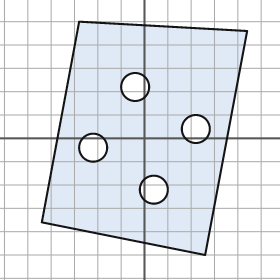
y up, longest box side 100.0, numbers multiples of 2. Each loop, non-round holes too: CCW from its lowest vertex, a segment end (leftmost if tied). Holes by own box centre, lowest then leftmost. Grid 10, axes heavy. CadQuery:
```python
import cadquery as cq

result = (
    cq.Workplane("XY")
    .moveTo(26.0, -50.0)
    .lineTo(44.0, 46.0)
    .lineTo(-28.0, 50.0)
    .lineTo(-44.0, -36.0)
    .close()
    .moveTo(4.0, -22.0)
    .circle(6.0)
    .moveTo(-22.0, -4.0)
    .circle(6.0)
    .moveTo(22.0, 4.0)
    .circle(6.0)
    .moveTo(-4.0, 22.0)
    .circle(6.0)
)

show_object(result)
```